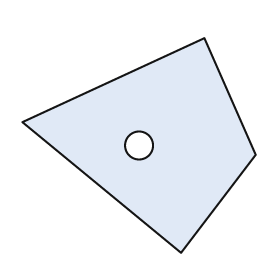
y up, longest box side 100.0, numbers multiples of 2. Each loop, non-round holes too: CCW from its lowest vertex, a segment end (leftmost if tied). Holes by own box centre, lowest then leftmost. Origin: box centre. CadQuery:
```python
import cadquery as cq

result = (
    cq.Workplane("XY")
    .moveTo(18.0, -46.0)
    .lineTo(50.0, -4.0)
    .lineTo(28.0, 46.0)
    .lineTo(-50.0, 10.0)
    .close()
    .moveTo(0.0, 0.0)
    .circle(6.0)
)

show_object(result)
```